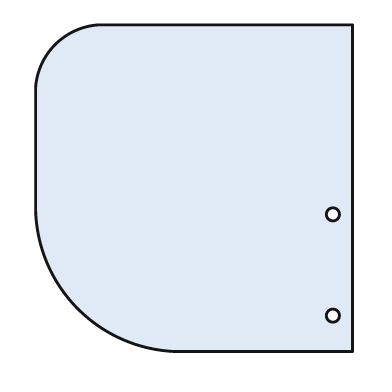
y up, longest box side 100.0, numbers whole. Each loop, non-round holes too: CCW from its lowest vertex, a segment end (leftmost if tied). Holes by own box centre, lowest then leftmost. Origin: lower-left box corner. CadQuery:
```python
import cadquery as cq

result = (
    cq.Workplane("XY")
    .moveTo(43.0, 0.0)
    .lineTo(97.0, 0.0)
    .lineTo(97.0, 100.0)
    .lineTo(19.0, 100.0)
    .threePointArc((6.0, 94.0), (0.0, 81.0))
    .lineTo(0.0, 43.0)
    .threePointArc((13.0, 13.0), (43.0, 0.0))
    .close()
    .moveTo(91.0, 11.0)
    .circle(2.0)
    .moveTo(91.0, 42.0)
    .circle(2.0)
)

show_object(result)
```